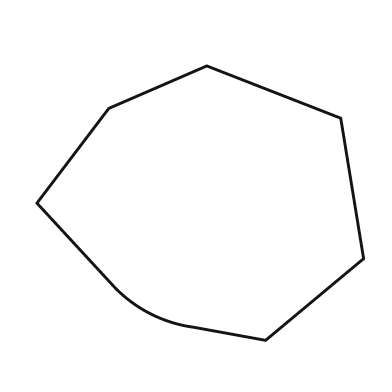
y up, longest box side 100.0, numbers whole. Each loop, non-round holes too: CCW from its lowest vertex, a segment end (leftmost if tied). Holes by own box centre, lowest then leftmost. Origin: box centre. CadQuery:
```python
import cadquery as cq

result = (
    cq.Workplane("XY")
    .moveTo(20.0, -42.0)
    .lineTo(50.0, -17.0)
    .lineTo(43.0, 26.0)
    .lineTo(2.0, 42.0)
    .lineTo(-28.0, 29.0)
    .lineTo(-50.0, 0.0)
    .lineTo(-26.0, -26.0)
    .threePointArc((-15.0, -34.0), (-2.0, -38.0))
    .close()
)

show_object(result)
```